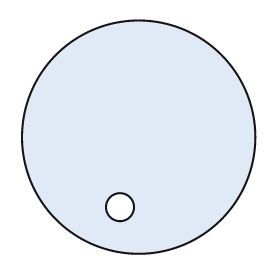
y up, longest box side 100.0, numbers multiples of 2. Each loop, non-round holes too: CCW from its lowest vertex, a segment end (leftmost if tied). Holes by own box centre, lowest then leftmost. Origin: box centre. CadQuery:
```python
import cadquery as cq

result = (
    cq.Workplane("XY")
    .moveTo(0.0, 0.0)
    .circle(50.0)
    .moveTo(-8.0, -30.0)
    .circle(6.0)
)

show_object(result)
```